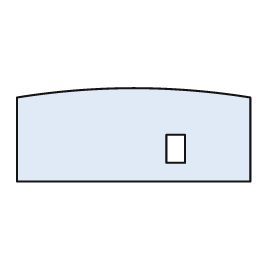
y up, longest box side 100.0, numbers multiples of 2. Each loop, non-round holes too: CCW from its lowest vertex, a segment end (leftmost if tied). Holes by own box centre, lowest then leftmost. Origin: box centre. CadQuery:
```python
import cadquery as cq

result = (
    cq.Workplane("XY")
    .moveTo(-50.0, -20.0)
    .lineTo(50.0, -20.0)
    .lineTo(50.0, 16.0)
    .threePointArc((0.0, 20.0), (-50.0, 16.0))
    .close()
    .moveTo(14.0, -12.0)
    .lineTo(22.0, -12.0)
    .lineTo(22.0, 0.0)
    .lineTo(14.0, 0.0)
    .close()
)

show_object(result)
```